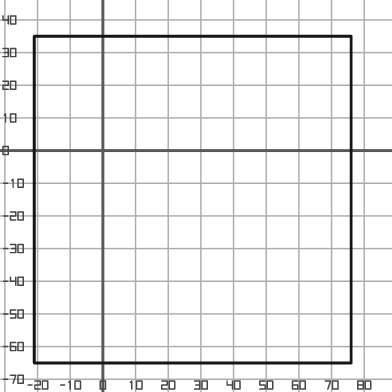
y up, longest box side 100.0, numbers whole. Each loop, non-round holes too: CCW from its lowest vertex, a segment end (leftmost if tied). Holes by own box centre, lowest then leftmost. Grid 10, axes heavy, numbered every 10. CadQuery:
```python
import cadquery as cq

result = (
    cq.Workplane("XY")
    .moveTo(-21.0, -65.0)
    .lineTo(76.0, -65.0)
    .lineTo(76.0, 35.0)
    .lineTo(-21.0, 35.0)
    .close()
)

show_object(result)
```